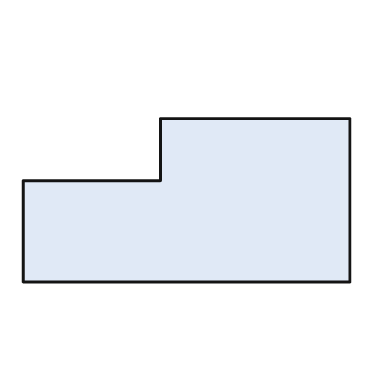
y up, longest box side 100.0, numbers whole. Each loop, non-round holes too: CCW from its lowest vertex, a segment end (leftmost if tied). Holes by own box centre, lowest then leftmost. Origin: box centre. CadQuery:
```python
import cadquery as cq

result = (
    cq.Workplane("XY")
    .moveTo(-50.0, -25.0)
    .lineTo(50.0, -25.0)
    .lineTo(50.0, 25.0)
    .lineTo(-8.0, 25.0)
    .lineTo(-8.0, 6.0)
    .lineTo(-50.0, 6.0)
    .close()
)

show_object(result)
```